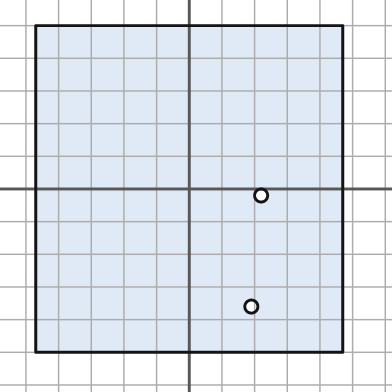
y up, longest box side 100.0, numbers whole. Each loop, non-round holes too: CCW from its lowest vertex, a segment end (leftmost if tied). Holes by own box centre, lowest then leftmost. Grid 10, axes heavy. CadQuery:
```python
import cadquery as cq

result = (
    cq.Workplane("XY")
    .moveTo(-47.0, -50.0)
    .lineTo(47.0, -50.0)
    .lineTo(47.0, 50.0)
    .lineTo(-47.0, 50.0)
    .close()
    .moveTo(19.0, -36.0)
    .circle(2.0)
    .moveTo(22.0, -2.0)
    .circle(2.0)
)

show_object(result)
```